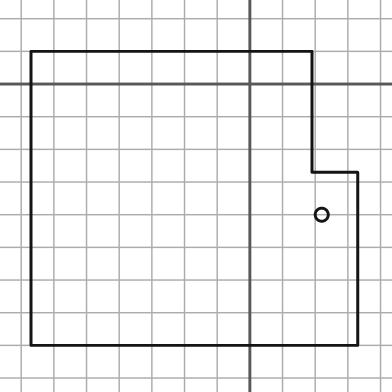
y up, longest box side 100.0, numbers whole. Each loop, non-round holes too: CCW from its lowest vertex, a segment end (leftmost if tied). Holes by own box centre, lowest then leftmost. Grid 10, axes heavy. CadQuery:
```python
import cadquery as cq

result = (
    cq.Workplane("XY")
    .moveTo(-67.0, -80.0)
    .lineTo(33.0, -80.0)
    .lineTo(33.0, -27.0)
    .lineTo(19.0, -27.0)
    .lineTo(19.0, 10.0)
    .lineTo(-67.0, 10.0)
    .close()
    .moveTo(22.0, -40.0)
    .circle(2.0)
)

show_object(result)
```